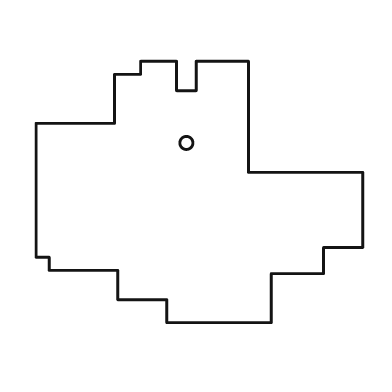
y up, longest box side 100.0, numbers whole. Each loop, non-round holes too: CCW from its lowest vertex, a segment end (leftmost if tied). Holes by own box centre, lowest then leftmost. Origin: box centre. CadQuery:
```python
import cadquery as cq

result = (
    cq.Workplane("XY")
    .moveTo(-10.0, -40.0)
    .lineTo(22.0, -40.0)
    .lineTo(22.0, -25.0)
    .lineTo(38.0, -25.0)
    .lineTo(38.0, -17.0)
    .lineTo(50.0, -17.0)
    .lineTo(50.0, 6.0)
    .lineTo(15.0, 6.0)
    .lineTo(15.0, 40.0)
    .lineTo(-1.0, 40.0)
    .lineTo(-1.0, 31.0)
    .lineTo(-7.0, 31.0)
    .lineTo(-7.0, 40.0)
    .lineTo(-18.0, 40.0)
    .lineTo(-18.0, 36.0)
    .lineTo(-26.0, 36.0)
    .lineTo(-26.0, 21.0)
    .lineTo(-50.0, 21.0)
    .lineTo(-50.0, -20.0)
    .lineTo(-46.0, -20.0)
    .lineTo(-46.0, -24.0)
    .lineTo(-25.0, -24.0)
    .lineTo(-25.0, -33.0)
    .lineTo(-10.0, -33.0)
    .close()
    .moveTo(-4.0, 15.0)
    .circle(2.0)
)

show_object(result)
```